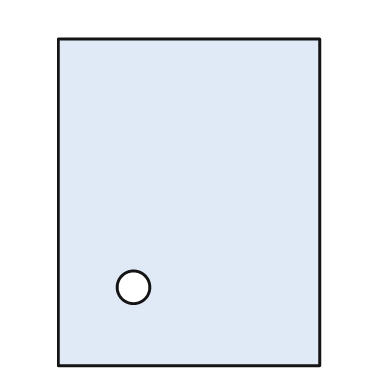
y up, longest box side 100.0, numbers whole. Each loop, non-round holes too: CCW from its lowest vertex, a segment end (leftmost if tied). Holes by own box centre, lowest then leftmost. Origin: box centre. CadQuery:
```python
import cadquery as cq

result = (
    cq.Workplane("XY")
    .moveTo(-40.0, -50.0)
    .lineTo(40.0, -50.0)
    .lineTo(40.0, 50.0)
    .lineTo(-40.0, 50.0)
    .close()
    .moveTo(-17.0, -26.0)
    .circle(5.0)
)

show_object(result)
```